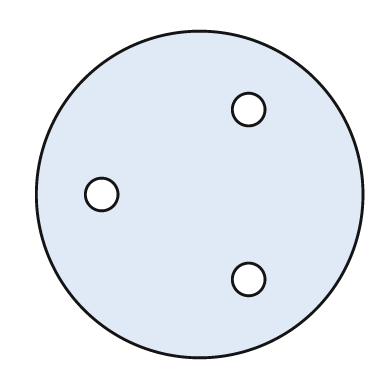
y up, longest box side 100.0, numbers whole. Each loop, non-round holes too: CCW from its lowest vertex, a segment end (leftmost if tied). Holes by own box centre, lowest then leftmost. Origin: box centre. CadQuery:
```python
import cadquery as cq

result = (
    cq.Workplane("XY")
    .moveTo(0.0, 0.0)
    .circle(50.0)
    .moveTo(15.0, -26.0)
    .circle(5.0)
    .moveTo(-30.0, 0.0)
    .circle(5.0)
    .moveTo(15.0, 26.0)
    .circle(5.0)
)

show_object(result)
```